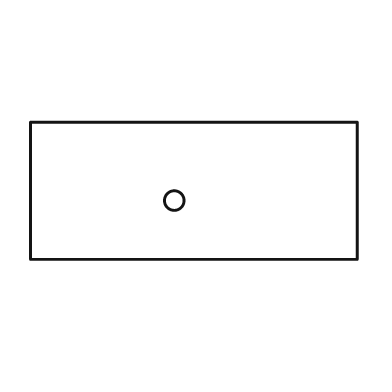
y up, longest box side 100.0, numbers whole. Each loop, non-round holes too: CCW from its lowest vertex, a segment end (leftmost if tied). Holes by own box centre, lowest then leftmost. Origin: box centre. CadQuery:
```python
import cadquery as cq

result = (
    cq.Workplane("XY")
    .moveTo(-50.0, -21.0)
    .lineTo(50.0, -21.0)
    .lineTo(50.0, 21.0)
    .lineTo(-50.0, 21.0)
    .close()
    .moveTo(-6.0, -3.0)
    .circle(3.0)
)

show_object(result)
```